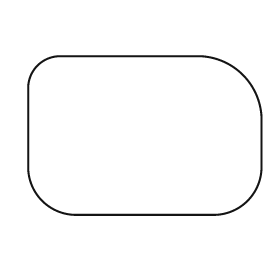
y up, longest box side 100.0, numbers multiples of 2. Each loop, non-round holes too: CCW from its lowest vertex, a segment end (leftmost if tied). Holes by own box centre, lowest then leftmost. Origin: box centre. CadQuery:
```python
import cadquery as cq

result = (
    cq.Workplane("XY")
    .moveTo(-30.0, -34.0)
    .lineTo(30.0, -34.0)
    .threePointArc((44.0, -28.0), (50.0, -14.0))
    .lineTo(50.0, 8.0)
    .threePointArc((42.0, 26.0), (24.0, 34.0))
    .lineTo(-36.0, 34.0)
    .threePointArc((-46.0, 30.0), (-50.0, 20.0))
    .lineTo(-50.0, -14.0)
    .threePointArc((-44.0, -28.0), (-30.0, -34.0))
    .close()
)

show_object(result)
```